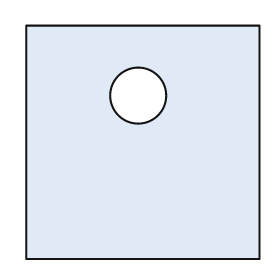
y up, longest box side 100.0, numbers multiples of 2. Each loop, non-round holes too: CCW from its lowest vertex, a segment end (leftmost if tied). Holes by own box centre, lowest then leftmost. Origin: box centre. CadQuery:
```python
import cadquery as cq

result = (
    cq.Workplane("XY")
    .moveTo(-50.0, -50.0)
    .lineTo(50.0, -50.0)
    .lineTo(50.0, 50.0)
    .lineTo(-50.0, 50.0)
    .close()
    .moveTo(-2.0, 20.0)
    .circle(12.0)
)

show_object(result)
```